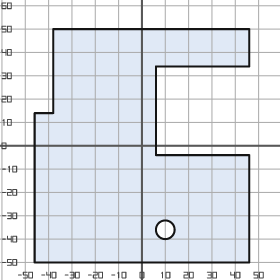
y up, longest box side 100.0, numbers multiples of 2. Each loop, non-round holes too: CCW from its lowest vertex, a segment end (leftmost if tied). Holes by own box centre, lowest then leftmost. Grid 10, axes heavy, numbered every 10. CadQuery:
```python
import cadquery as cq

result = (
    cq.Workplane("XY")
    .moveTo(-46.0, -50.0)
    .lineTo(46.0, -50.0)
    .lineTo(46.0, -4.0)
    .lineTo(6.0, -4.0)
    .lineTo(6.0, 34.0)
    .lineTo(46.0, 34.0)
    .lineTo(46.0, 50.0)
    .lineTo(-38.0, 50.0)
    .lineTo(-38.0, 14.0)
    .lineTo(-46.0, 14.0)
    .close()
    .moveTo(10.0, -36.0)
    .circle(4.0)
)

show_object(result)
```